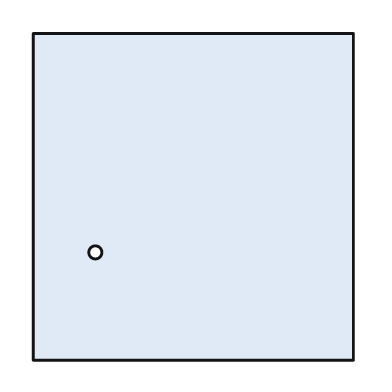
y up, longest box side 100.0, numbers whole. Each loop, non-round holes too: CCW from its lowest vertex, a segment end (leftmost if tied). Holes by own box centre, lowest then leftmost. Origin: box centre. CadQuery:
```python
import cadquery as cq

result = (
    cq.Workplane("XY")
    .moveTo(-49.0, -50.0)
    .lineTo(49.0, -50.0)
    .lineTo(49.0, 50.0)
    .lineTo(-49.0, 50.0)
    .close()
    .moveTo(-30.0, -17.0)
    .circle(2.0)
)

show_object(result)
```